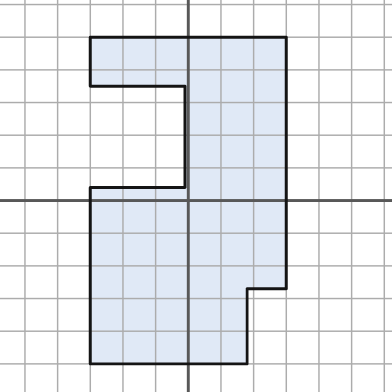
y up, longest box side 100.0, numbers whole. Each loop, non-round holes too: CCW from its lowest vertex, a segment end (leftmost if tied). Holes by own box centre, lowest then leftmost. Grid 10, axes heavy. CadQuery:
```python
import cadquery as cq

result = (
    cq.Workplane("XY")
    .moveTo(-30.0, -50.0)
    .lineTo(18.0, -50.0)
    .lineTo(18.0, -27.0)
    .lineTo(30.0, -27.0)
    .lineTo(30.0, 50.0)
    .lineTo(-30.0, 50.0)
    .lineTo(-30.0, 35.0)
    .lineTo(-1.0, 35.0)
    .lineTo(-1.0, 4.0)
    .lineTo(-30.0, 4.0)
    .close()
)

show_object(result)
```